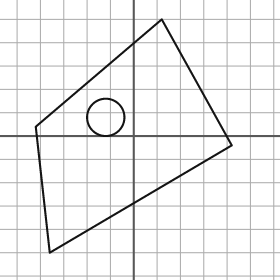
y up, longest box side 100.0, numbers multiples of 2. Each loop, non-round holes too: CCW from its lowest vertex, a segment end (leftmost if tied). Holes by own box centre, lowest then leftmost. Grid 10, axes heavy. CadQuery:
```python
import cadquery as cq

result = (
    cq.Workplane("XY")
    .moveTo(-36.0, -50.0)
    .lineTo(42.0, -4.0)
    .lineTo(12.0, 50.0)
    .lineTo(-42.0, 4.0)
    .close()
    .moveTo(-12.0, 8.0)
    .circle(8.0)
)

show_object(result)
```